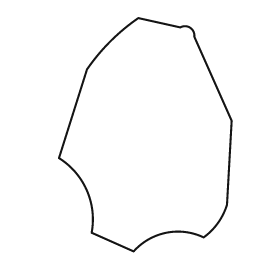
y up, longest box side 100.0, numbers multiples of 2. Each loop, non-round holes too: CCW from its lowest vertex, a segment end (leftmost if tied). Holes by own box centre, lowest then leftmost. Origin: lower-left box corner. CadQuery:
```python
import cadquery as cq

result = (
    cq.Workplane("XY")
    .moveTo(32.0, 0.0)
    .threePointArc((46.0, 8.0), (62.0, 6.0))
    .threePointArc((68.0, 12.0), (72.0, 20.0))
    .lineTo(74.0, 56.0)
    .lineTo(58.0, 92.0)
    .threePointArc((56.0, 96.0), (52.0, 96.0))
    .lineTo(34.0, 100.0)
    .threePointArc((22.0, 90.0), (12.0, 78.0))
    .lineTo(0.0, 40.0)
    .threePointArc((12.0, 26.0), (14.0, 8.0))
    .close()
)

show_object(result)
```